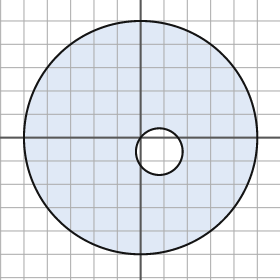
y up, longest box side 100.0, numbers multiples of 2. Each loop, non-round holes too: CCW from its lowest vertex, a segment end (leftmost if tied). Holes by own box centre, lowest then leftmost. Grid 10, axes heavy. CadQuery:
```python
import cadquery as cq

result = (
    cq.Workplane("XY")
    .moveTo(0.0, 0.0)
    .circle(50.0)
    .moveTo(8.0, -6.0)
    .circle(10.0)
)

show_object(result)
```